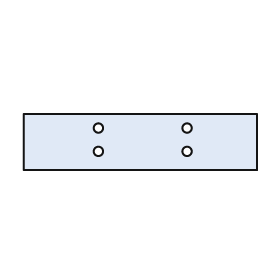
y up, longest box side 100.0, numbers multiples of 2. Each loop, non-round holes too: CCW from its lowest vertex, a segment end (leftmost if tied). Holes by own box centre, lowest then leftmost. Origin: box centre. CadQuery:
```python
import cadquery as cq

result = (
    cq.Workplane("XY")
    .moveTo(-50.0, -12.0)
    .lineTo(50.0, -12.0)
    .lineTo(50.0, 12.0)
    .lineTo(-50.0, 12.0)
    .close()
    .moveTo(-18.0, -4.0)
    .circle(2.0)
    .moveTo(20.0, -4.0)
    .circle(2.0)
    .moveTo(-18.0, 6.0)
    .circle(2.0)
    .moveTo(20.0, 6.0)
    .circle(2.0)
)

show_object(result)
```